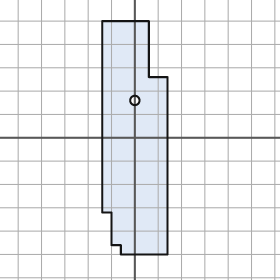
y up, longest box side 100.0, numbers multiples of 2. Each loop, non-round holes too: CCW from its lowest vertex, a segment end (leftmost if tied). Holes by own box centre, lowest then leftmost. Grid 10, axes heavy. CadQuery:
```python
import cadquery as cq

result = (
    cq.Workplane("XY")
    .moveTo(-6.0, -50.0)
    .lineTo(14.0, -50.0)
    .lineTo(14.0, 26.0)
    .lineTo(6.0, 26.0)
    .lineTo(6.0, 50.0)
    .lineTo(-14.0, 50.0)
    .lineTo(-14.0, -32.0)
    .lineTo(-10.0, -32.0)
    .lineTo(-10.0, -46.0)
    .lineTo(-6.0, -46.0)
    .close()
    .moveTo(0.0, 16.0)
    .circle(2.0)
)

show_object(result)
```